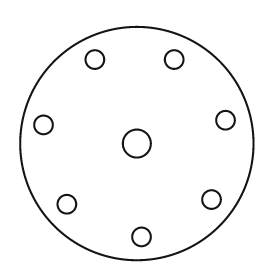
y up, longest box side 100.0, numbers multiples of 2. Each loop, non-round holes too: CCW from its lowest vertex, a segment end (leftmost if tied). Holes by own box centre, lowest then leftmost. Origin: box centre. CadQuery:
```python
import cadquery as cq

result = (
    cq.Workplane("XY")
    .moveTo(0.0, 0.0)
    .circle(50.0)
    .moveTo(2.0, -40.0)
    .circle(4.0)
    .moveTo(-30.0, -26.0)
    .circle(4.0)
    .moveTo(32.0, -24.0)
    .circle(4.0)
    .moveTo(0.0, 0.0)
    .circle(6.0)
    .moveTo(-40.0, 8.0)
    .circle(4.0)
    .moveTo(38.0, 10.0)
    .circle(4.0)
    .moveTo(-18.0, 36.0)
    .circle(4.0)
    .moveTo(16.0, 36.0)
    .circle(4.0)
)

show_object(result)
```